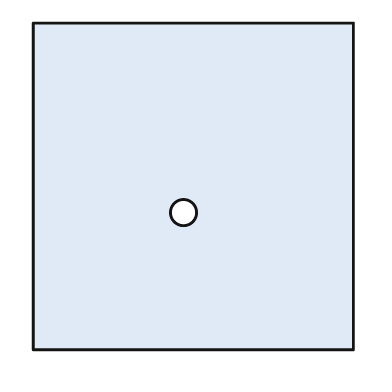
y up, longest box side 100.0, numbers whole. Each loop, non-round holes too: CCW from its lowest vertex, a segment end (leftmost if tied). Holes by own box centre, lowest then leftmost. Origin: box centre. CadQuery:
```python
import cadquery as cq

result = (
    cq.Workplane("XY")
    .moveTo(-49.0, -50.0)
    .lineTo(49.0, -50.0)
    .lineTo(49.0, 50.0)
    .lineTo(-49.0, 50.0)
    .close()
    .moveTo(-3.0, -8.0)
    .circle(4.0)
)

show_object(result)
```